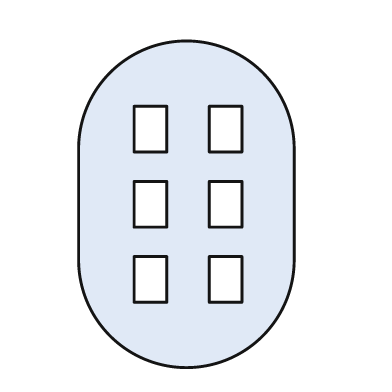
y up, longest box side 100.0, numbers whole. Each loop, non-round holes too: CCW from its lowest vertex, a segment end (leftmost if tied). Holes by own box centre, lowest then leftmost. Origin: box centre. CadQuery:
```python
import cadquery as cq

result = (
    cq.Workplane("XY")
    .moveTo(-33.0, -17.0)
    .threePointArc((0.0, -50.0), (33.0, -17.0))
    .lineTo(33.0, 17.0)
    .threePointArc((0.0, 50.0), (-33.0, 17.0))
    .close()
    .moveTo(-16.0, -30.0)
    .lineTo(-6.0, -30.0)
    .lineTo(-6.0, -16.0)
    .lineTo(-16.0, -16.0)
    .close()
    .moveTo(7.0, -30.0)
    .lineTo(17.0, -30.0)
    .lineTo(17.0, -16.0)
    .lineTo(7.0, -16.0)
    .close()
    .moveTo(-16.0, -7.0)
    .lineTo(-6.0, -7.0)
    .lineTo(-6.0, 7.0)
    .lineTo(-16.0, 7.0)
    .close()
    .moveTo(7.0, -7.0)
    .lineTo(17.0, -7.0)
    .lineTo(17.0, 7.0)
    .lineTo(7.0, 7.0)
    .close()
    .moveTo(-16.0, 16.0)
    .lineTo(-6.0, 16.0)
    .lineTo(-6.0, 30.0)
    .lineTo(-16.0, 30.0)
    .close()
    .moveTo(7.0, 16.0)
    .lineTo(17.0, 16.0)
    .lineTo(17.0, 30.0)
    .lineTo(7.0, 30.0)
    .close()
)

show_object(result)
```